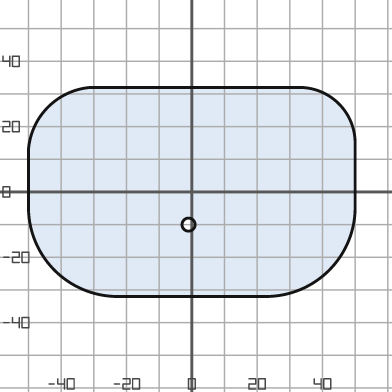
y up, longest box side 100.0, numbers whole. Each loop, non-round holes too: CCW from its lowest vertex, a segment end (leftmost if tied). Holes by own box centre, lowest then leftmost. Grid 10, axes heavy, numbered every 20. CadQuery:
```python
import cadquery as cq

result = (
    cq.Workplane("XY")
    .moveTo(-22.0, -32.0)
    .lineTo(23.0, -32.0)
    .threePointArc((42.0, -24.0), (50.0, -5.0))
    .lineTo(50.0, 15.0)
    .threePointArc((45.0, 27.0), (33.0, 32.0))
    .lineTo(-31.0, 32.0)
    .threePointArc((-44.0, 26.0), (-50.0, 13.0))
    .lineTo(-50.0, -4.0)
    .threePointArc((-42.0, -24.0), (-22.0, -32.0))
    .close()
    .moveTo(-1.0, -10.0)
    .circle(2.0)
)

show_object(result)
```